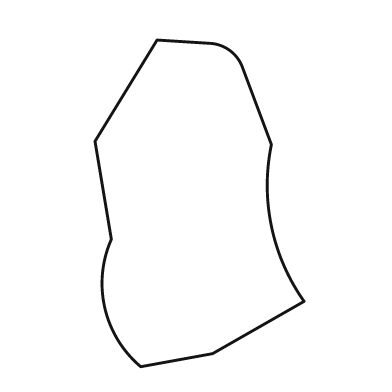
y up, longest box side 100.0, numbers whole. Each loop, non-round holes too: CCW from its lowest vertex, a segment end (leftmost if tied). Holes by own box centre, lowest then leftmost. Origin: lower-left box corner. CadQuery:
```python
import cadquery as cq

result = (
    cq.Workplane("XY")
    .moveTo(14.0, 0.0)
    .lineTo(36.0, 4.0)
    .lineTo(64.0, 20.0)
    .threePointArc((54.0, 43.0), (54.0, 68.0))
    .lineTo(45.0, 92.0)
    .threePointArc((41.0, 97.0), (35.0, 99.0))
    .lineTo(19.0, 100.0)
    .lineTo(0.0, 69.0)
    .lineTo(5.0, 39.0)
    .threePointArc((3.0, 18.0), (14.0, 0.0))
    .close()
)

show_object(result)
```